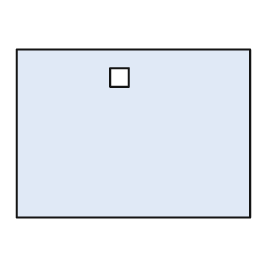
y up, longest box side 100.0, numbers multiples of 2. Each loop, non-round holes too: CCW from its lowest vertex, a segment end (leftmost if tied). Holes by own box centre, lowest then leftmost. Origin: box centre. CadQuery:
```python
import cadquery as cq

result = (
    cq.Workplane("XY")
    .moveTo(-50.0, -36.0)
    .lineTo(50.0, -36.0)
    .lineTo(50.0, 36.0)
    .lineTo(-50.0, 36.0)
    .close()
    .moveTo(-10.0, 20.0)
    .lineTo(-2.0, 20.0)
    .lineTo(-2.0, 28.0)
    .lineTo(-10.0, 28.0)
    .close()
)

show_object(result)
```